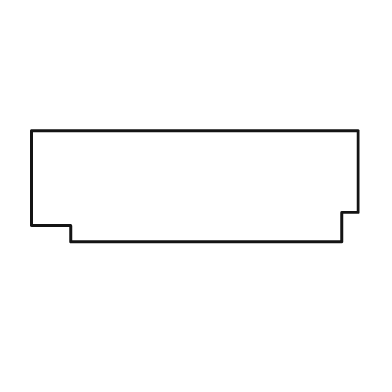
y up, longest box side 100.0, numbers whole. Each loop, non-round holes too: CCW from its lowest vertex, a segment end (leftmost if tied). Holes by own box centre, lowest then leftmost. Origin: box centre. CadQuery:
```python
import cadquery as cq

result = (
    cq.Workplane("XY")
    .moveTo(-38.0, -17.0)
    .lineTo(45.0, -17.0)
    .lineTo(45.0, -8.0)
    .lineTo(50.0, -8.0)
    .lineTo(50.0, 17.0)
    .lineTo(-50.0, 17.0)
    .lineTo(-50.0, -12.0)
    .lineTo(-38.0, -12.0)
    .close()
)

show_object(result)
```